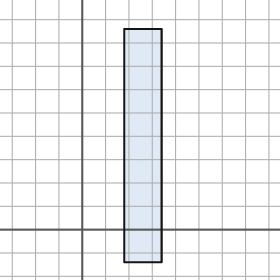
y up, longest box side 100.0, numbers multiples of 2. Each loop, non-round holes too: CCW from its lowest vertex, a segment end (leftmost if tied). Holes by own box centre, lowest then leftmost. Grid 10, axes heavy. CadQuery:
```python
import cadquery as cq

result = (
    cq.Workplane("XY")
    .moveTo(18.0, -14.0)
    .lineTo(34.0, -14.0)
    .lineTo(34.0, 86.0)
    .lineTo(18.0, 86.0)
    .close()
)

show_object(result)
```